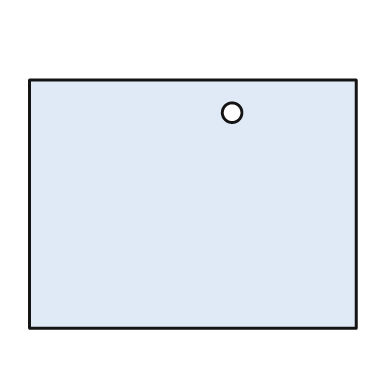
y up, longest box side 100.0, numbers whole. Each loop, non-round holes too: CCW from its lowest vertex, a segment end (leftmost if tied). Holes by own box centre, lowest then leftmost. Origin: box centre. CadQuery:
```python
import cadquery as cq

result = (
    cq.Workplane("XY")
    .moveTo(-50.0, -38.0)
    .lineTo(50.0, -38.0)
    .lineTo(50.0, 38.0)
    .lineTo(-50.0, 38.0)
    .close()
    .moveTo(12.0, 28.0)
    .circle(3.0)
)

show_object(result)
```